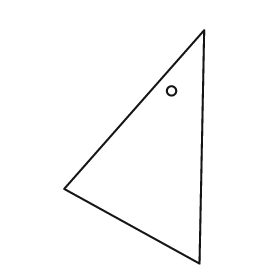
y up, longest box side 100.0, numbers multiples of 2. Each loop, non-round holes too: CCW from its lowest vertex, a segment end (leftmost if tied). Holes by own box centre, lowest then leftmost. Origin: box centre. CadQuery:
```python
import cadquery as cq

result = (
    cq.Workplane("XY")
    .moveTo(28.0, -50.0)
    .lineTo(30.0, 50.0)
    .lineTo(-30.0, -18.0)
    .close()
    .moveTo(16.0, 24.0)
    .circle(2.0)
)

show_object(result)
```